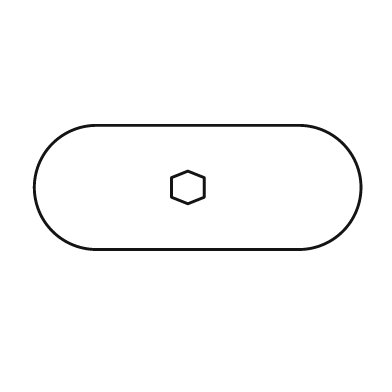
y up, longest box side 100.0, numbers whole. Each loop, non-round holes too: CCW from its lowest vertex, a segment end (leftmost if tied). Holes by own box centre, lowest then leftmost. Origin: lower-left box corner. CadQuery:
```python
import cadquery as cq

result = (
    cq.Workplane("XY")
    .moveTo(19.0, 0.0)
    .lineTo(81.0, 0.0)
    .threePointArc((100.0, 19.0), (81.0, 38.0))
    .lineTo(19.0, 38.0)
    .threePointArc((0.0, 19.0), (19.0, 0.0))
    .close()
    .moveTo(47.0, 14.0)
    .lineTo(52.0, 16.0)
    .lineTo(52.0, 22.0)
    .lineTo(47.0, 24.0)
    .lineTo(42.0, 22.0)
    .lineTo(42.0, 16.0)
    .close()
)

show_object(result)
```